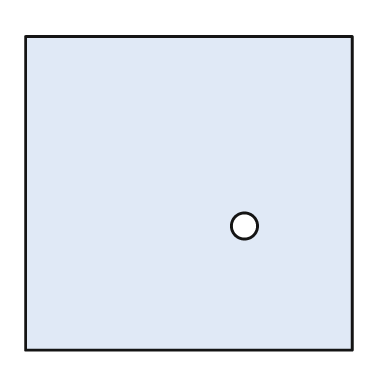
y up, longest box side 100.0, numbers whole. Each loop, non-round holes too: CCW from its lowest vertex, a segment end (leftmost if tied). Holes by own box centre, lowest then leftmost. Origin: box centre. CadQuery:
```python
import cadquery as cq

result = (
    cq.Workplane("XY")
    .moveTo(-50.0, -48.0)
    .lineTo(50.0, -48.0)
    .lineTo(50.0, 48.0)
    .lineTo(-50.0, 48.0)
    .close()
    .moveTo(17.0, -10.0)
    .circle(4.0)
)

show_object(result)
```